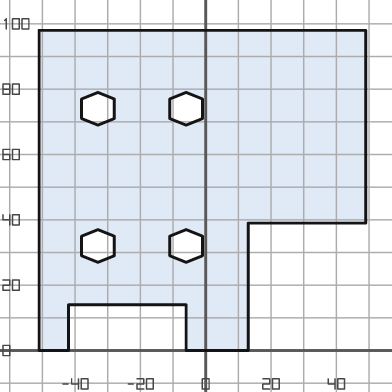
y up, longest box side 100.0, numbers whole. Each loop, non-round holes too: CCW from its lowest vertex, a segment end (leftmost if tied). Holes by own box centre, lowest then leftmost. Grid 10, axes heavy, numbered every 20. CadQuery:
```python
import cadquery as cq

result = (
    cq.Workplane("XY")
    .moveTo(-51.0, 0.0)
    .lineTo(-42.0, 0.0)
    .lineTo(-42.0, 14.0)
    .lineTo(-6.0, 14.0)
    .lineTo(-6.0, 0.0)
    .lineTo(13.0, 0.0)
    .lineTo(13.0, 39.0)
    .lineTo(49.0, 39.0)
    .lineTo(49.0, 98.0)
    .lineTo(-51.0, 98.0)
    .close()
    .moveTo(-33.0, 27.0)
    .lineTo(-28.0, 29.0)
    .lineTo(-28.0, 35.0)
    .lineTo(-33.0, 37.0)
    .lineTo(-38.0, 35.0)
    .lineTo(-38.0, 29.0)
    .close()
    .moveTo(-6.0, 27.0)
    .lineTo(-1.0, 29.0)
    .lineTo(-1.0, 35.0)
    .lineTo(-6.0, 37.0)
    .lineTo(-11.0, 35.0)
    .lineTo(-11.0, 29.0)
    .close()
    .moveTo(-33.0, 69.0)
    .lineTo(-28.0, 71.0)
    .lineTo(-28.0, 77.0)
    .lineTo(-33.0, 79.0)
    .lineTo(-38.0, 77.0)
    .lineTo(-38.0, 71.0)
    .close()
    .moveTo(-6.0, 69.0)
    .lineTo(-1.0, 71.0)
    .lineTo(-1.0, 77.0)
    .lineTo(-6.0, 79.0)
    .lineTo(-11.0, 77.0)
    .lineTo(-11.0, 71.0)
    .close()
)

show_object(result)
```